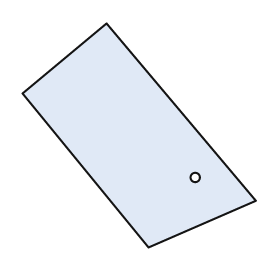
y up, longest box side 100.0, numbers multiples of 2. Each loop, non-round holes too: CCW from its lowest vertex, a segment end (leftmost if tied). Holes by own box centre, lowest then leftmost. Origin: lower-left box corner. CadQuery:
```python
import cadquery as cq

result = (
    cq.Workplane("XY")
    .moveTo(54.0, 0.0)
    .lineTo(100.0, 20.0)
    .lineTo(36.0, 96.0)
    .lineTo(0.0, 66.0)
    .close()
    .moveTo(74.0, 30.0)
    .circle(2.0)
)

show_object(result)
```